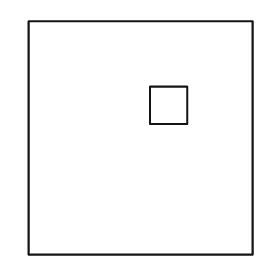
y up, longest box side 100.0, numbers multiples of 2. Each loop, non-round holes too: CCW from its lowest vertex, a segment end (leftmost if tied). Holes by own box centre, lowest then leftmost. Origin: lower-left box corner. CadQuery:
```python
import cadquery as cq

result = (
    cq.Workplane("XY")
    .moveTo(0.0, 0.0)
    .lineTo(96.0, 0.0)
    .lineTo(96.0, 100.0)
    .lineTo(0.0, 100.0)
    .close()
    .moveTo(52.0, 56.0)
    .lineTo(68.0, 56.0)
    .lineTo(68.0, 72.0)
    .lineTo(52.0, 72.0)
    .close()
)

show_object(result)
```